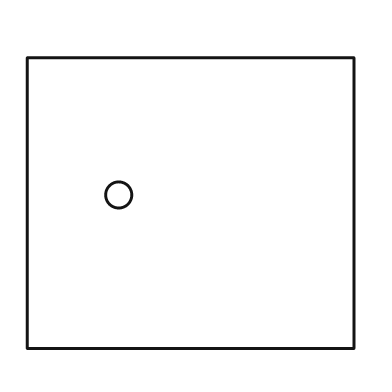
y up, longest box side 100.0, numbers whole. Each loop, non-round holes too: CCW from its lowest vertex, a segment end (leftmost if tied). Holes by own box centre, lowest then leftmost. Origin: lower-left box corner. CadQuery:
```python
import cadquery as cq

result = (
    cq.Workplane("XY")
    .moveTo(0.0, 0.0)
    .lineTo(100.0, 0.0)
    .lineTo(100.0, 89.0)
    .lineTo(0.0, 89.0)
    .close()
    .moveTo(28.0, 47.0)
    .circle(4.0)
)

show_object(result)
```